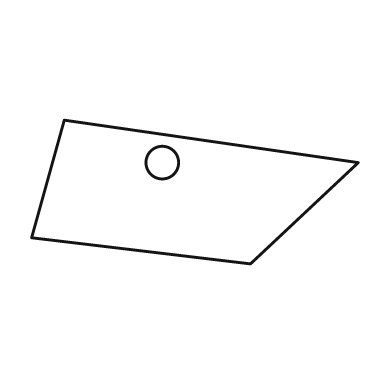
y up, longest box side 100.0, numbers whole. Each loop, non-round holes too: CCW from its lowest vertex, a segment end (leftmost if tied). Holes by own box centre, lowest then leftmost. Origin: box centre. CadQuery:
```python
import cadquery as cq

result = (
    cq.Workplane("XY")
    .moveTo(17.0, -22.0)
    .lineTo(50.0, 9.0)
    .lineTo(-40.0, 22.0)
    .lineTo(-50.0, -14.0)
    .close()
    .moveTo(-10.0, 9.0)
    .circle(5.0)
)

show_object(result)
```